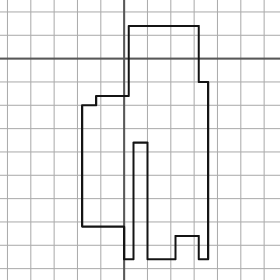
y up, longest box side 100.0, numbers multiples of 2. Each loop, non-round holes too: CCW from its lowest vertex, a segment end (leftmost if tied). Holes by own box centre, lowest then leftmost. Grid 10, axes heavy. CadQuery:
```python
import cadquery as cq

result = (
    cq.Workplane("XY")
    .moveTo(0.0, -86.0)
    .lineTo(4.0, -86.0)
    .lineTo(4.0, -36.0)
    .lineTo(10.0, -36.0)
    .lineTo(10.0, -86.0)
    .lineTo(22.0, -86.0)
    .lineTo(22.0, -76.0)
    .lineTo(32.0, -76.0)
    .lineTo(32.0, -86.0)
    .lineTo(36.0, -86.0)
    .lineTo(36.0, -10.0)
    .lineTo(32.0, -10.0)
    .lineTo(32.0, 14.0)
    .lineTo(2.0, 14.0)
    .lineTo(2.0, -16.0)
    .lineTo(-12.0, -16.0)
    .lineTo(-12.0, -20.0)
    .lineTo(-18.0, -20.0)
    .lineTo(-18.0, -72.0)
    .lineTo(0.0, -72.0)
    .close()
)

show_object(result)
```